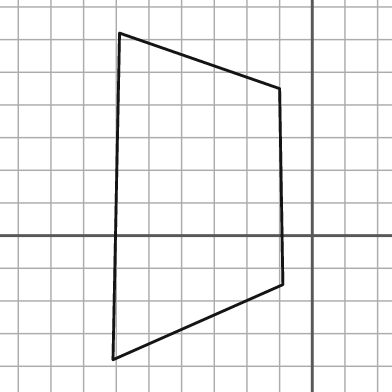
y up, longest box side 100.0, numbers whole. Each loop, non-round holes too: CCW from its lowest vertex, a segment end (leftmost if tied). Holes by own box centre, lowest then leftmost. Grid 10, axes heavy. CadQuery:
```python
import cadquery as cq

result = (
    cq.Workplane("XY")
    .moveTo(-61.0, -38.0)
    .lineTo(-9.0, -15.0)
    .lineTo(-10.0, 45.0)
    .lineTo(-59.0, 62.0)
    .close()
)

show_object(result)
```